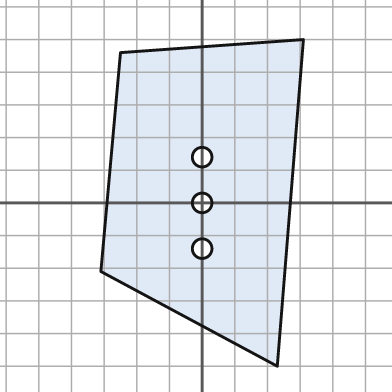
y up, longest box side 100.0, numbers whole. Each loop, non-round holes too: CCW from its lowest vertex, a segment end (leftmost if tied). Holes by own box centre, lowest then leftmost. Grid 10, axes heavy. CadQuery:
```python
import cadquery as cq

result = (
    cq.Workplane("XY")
    .moveTo(23.0, -50.0)
    .lineTo(31.0, 50.0)
    .lineTo(-25.0, 46.0)
    .lineTo(-31.0, -21.0)
    .close()
    .moveTo(0.0, -14.0)
    .circle(3.0)
    .moveTo(0.0, 0.0)
    .circle(3.0)
    .moveTo(0.0, 14.0)
    .circle(3.0)
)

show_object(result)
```